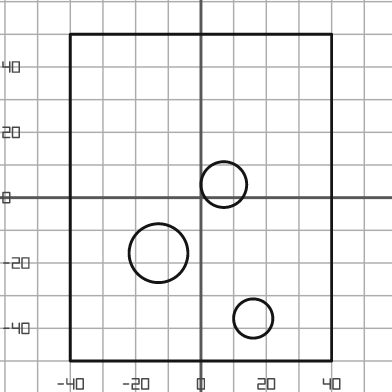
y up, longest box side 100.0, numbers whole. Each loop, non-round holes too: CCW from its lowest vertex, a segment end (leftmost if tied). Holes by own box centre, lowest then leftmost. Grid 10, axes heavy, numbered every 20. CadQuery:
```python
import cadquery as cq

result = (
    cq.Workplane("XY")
    .moveTo(-40.0, -50.0)
    .lineTo(40.0, -50.0)
    .lineTo(40.0, 50.0)
    .lineTo(-40.0, 50.0)
    .close()
    .moveTo(16.0, -37.0)
    .circle(6.0)
    .moveTo(-13.0, -17.0)
    .circle(9.0)
    .moveTo(7.0, 4.0)
    .circle(7.0)
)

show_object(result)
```